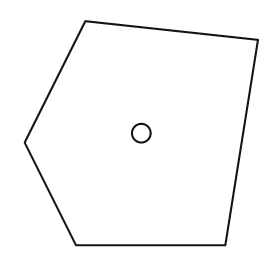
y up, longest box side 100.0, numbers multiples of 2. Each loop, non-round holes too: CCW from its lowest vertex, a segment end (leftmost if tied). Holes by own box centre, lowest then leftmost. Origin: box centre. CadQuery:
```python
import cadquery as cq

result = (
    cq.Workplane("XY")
    .moveTo(-28.0, -48.0)
    .lineTo(36.0, -48.0)
    .lineTo(50.0, 40.0)
    .lineTo(-24.0, 48.0)
    .lineTo(-50.0, -4.0)
    .close()
    .moveTo(0.0, 0.0)
    .circle(4.0)
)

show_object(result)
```